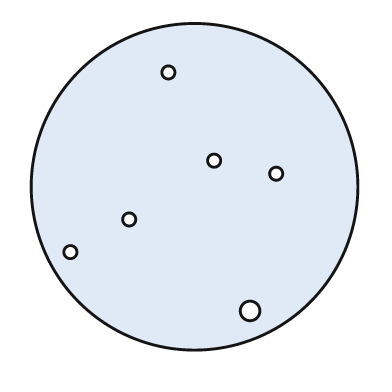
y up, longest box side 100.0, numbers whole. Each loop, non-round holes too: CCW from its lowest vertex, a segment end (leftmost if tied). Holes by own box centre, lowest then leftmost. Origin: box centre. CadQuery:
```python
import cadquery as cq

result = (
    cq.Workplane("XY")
    .moveTo(0.0, 0.0)
    .circle(50.0)
    .moveTo(17.0, -38.0)
    .circle(3.0)
    .moveTo(-38.0, -20.0)
    .circle(2.0)
    .moveTo(-20.0, -10.0)
    .circle(2.0)
    .moveTo(25.0, 4.0)
    .circle(2.0)
    .moveTo(6.0, 8.0)
    .circle(2.0)
    .moveTo(-8.0, 35.0)
    .circle(2.0)
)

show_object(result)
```